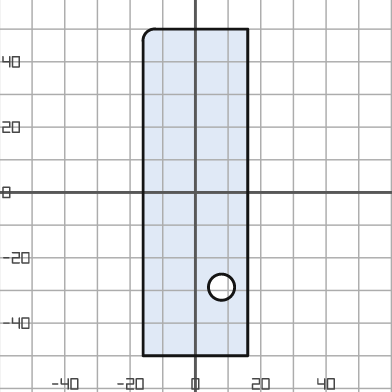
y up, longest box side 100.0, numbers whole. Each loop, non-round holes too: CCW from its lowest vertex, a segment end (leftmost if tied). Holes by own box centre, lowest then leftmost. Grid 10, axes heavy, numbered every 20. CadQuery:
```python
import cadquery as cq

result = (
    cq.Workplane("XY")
    .moveTo(-16.0, -50.0)
    .lineTo(16.0, -50.0)
    .lineTo(16.0, 50.0)
    .lineTo(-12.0, 50.0)
    .threePointArc((-15.0, 49.0), (-16.0, 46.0))
    .close()
    .moveTo(8.0, -29.0)
    .circle(4.0)
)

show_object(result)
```